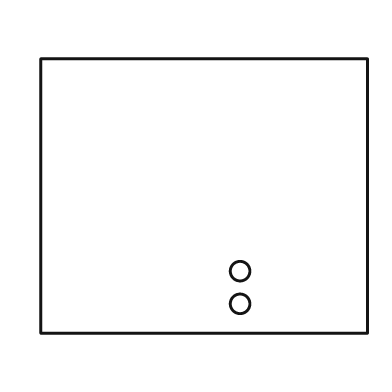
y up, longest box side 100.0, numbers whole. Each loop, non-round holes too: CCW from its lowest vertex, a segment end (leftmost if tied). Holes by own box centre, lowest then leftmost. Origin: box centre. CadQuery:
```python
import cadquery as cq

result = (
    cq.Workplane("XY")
    .moveTo(-50.0, -42.0)
    .lineTo(50.0, -42.0)
    .lineTo(50.0, 42.0)
    .lineTo(-50.0, 42.0)
    .close()
    .moveTo(11.0, -33.0)
    .circle(3.0)
    .moveTo(11.0, -23.0)
    .circle(3.0)
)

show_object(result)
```